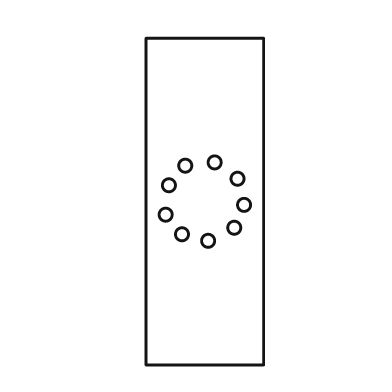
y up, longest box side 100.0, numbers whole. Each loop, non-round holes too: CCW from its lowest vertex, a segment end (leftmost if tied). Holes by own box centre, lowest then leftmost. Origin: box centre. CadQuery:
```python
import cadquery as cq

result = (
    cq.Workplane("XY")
    .moveTo(-18.0, -50.0)
    .lineTo(18.0, -50.0)
    .lineTo(18.0, 50.0)
    .lineTo(-18.0, 50.0)
    .close()
    .moveTo(1.0, -12.0)
    .circle(2.0)
    .moveTo(-7.0, -10.0)
    .circle(2.0)
    .moveTo(9.0, -8.0)
    .circle(2.0)
    .moveTo(-12.0, -4.0)
    .circle(2.0)
    .moveTo(12.0, -1.0)
    .circle(2.0)
    .moveTo(-11.0, 5.0)
    .circle(2.0)
    .moveTo(10.0, 7.0)
    .circle(2.0)
    .moveTo(-6.0, 11.0)
    .circle(2.0)
    .moveTo(3.0, 12.0)
    .circle(2.0)
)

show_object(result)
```